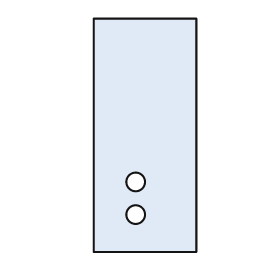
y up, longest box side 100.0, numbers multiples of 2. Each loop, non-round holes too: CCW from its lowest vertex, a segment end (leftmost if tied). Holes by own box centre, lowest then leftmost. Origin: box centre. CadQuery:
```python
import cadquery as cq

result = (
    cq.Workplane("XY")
    .moveTo(-22.0, -50.0)
    .lineTo(22.0, -50.0)
    .lineTo(22.0, 50.0)
    .lineTo(-22.0, 50.0)
    .close()
    .moveTo(-4.0, -34.0)
    .circle(4.0)
    .moveTo(-4.0, -20.0)
    .circle(4.0)
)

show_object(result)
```